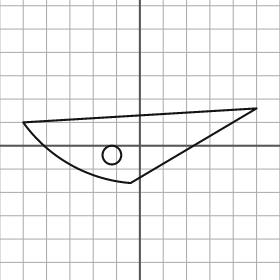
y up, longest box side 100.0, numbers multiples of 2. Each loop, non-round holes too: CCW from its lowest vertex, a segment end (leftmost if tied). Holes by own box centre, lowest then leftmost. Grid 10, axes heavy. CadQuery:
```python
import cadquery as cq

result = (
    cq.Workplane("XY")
    .moveTo(-4.0, -16.0)
    .lineTo(50.0, 16.0)
    .lineTo(-50.0, 10.0)
    .threePointArc((-30.0, -8.0), (-4.0, -16.0))
    .close()
    .moveTo(-12.0, -4.0)
    .circle(4.0)
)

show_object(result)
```